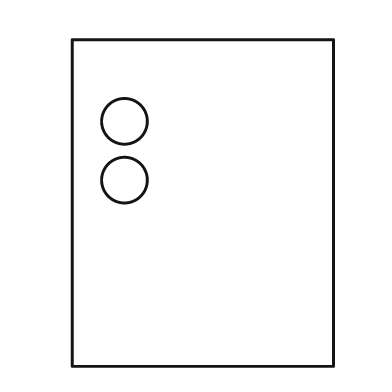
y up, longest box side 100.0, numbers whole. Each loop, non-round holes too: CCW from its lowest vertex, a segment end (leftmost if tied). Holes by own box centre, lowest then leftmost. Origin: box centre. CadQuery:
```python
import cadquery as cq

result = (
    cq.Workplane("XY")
    .moveTo(-40.0, -50.0)
    .lineTo(40.0, -50.0)
    .lineTo(40.0, 50.0)
    .lineTo(-40.0, 50.0)
    .close()
    .moveTo(-24.0, 7.0)
    .circle(7.0)
    .moveTo(-24.0, 25.0)
    .circle(7.0)
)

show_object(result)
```